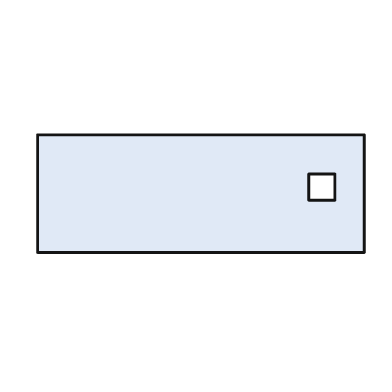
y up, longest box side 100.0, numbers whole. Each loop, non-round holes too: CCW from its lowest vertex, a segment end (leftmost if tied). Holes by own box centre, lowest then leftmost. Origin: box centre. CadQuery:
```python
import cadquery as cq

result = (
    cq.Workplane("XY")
    .moveTo(-50.0, -18.0)
    .lineTo(50.0, -18.0)
    .lineTo(50.0, 18.0)
    .lineTo(-50.0, 18.0)
    .close()
    .moveTo(33.0, -2.0)
    .lineTo(41.0, -2.0)
    .lineTo(41.0, 6.0)
    .lineTo(33.0, 6.0)
    .close()
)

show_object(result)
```